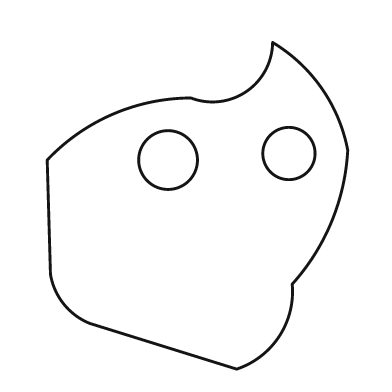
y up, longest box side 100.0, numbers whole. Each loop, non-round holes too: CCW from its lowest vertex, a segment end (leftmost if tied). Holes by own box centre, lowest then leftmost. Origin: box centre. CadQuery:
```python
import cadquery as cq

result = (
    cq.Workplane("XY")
    .moveTo(12.0, -50.0)
    .threePointArc((25.0, -40.0), (29.0, -24.0))
    .threePointArc((41.0, -5.0), (46.0, 17.0))
    .threePointArc((38.0, 36.0), (23.0, 50.0))
    .threePointArc((15.0, 35.0), (-2.0, 33.0))
    .threePointArc((-26.0, 28.0), (-46.0, 14.0))
    .lineTo(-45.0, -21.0)
    .threePointArc((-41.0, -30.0), (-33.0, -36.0))
    .close()
    .moveTo(-9.0, 14.0)
    .circle(9.0)
    .moveTo(28.0, 16.0)
    .circle(8.0)
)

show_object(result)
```